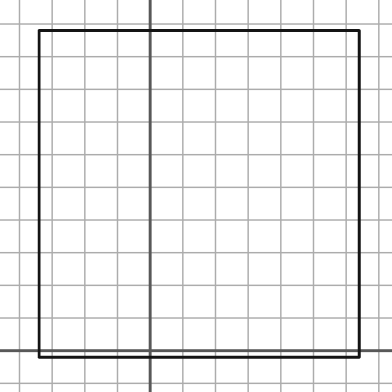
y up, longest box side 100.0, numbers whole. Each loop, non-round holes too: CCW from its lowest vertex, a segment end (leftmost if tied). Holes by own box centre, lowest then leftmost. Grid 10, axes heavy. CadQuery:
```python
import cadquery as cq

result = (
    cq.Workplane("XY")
    .moveTo(-34.0, -2.0)
    .lineTo(64.0, -2.0)
    .lineTo(64.0, 98.0)
    .lineTo(-34.0, 98.0)
    .close()
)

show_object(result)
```